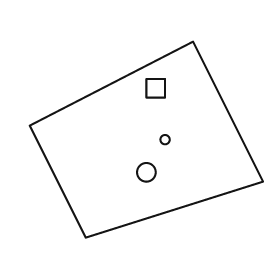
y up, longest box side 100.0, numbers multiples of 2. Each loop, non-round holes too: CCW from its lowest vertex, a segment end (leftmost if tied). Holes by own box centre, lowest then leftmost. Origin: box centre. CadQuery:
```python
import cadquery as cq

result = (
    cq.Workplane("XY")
    .moveTo(-26.0, -42.0)
    .lineTo(50.0, -18.0)
    .lineTo(20.0, 42.0)
    .lineTo(-50.0, 6.0)
    .close()
    .moveTo(0.0, -14.0)
    .circle(4.0)
    .moveTo(8.0, 0.0)
    .circle(2.0)
    .moveTo(0.0, 18.0)
    .lineTo(8.0, 18.0)
    .lineTo(8.0, 26.0)
    .lineTo(0.0, 26.0)
    .close()
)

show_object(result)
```